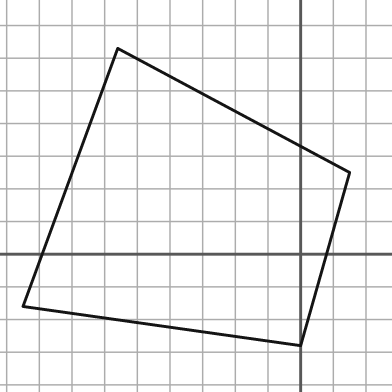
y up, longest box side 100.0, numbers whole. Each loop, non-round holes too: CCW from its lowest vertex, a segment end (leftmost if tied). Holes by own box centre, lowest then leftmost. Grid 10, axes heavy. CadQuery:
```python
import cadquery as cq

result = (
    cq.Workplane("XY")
    .moveTo(0.0, -28.0)
    .lineTo(15.0, 25.0)
    .lineTo(-56.0, 63.0)
    .lineTo(-85.0, -16.0)
    .close()
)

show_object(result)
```